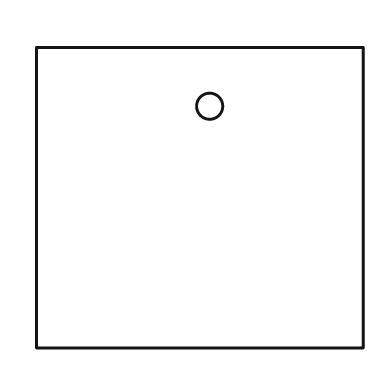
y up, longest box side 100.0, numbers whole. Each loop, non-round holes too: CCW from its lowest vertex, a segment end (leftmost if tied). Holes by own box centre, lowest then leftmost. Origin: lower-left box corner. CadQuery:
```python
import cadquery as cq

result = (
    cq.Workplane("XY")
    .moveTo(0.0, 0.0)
    .lineTo(100.0, 0.0)
    .lineTo(100.0, 92.0)
    .lineTo(0.0, 92.0)
    .close()
    .moveTo(53.0, 74.0)
    .circle(4.0)
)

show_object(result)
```